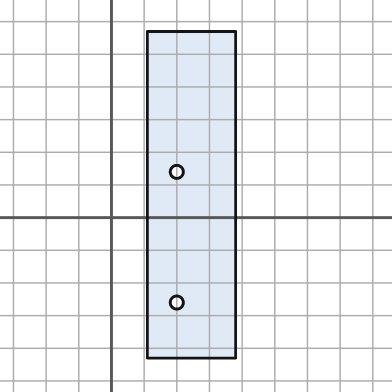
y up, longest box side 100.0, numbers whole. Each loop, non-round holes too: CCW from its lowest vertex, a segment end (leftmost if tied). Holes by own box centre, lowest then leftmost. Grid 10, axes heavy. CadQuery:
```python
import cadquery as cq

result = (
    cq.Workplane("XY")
    .moveTo(11.0, -43.0)
    .lineTo(38.0, -43.0)
    .lineTo(38.0, 57.0)
    .lineTo(11.0, 57.0)
    .close()
    .moveTo(20.0, -26.0)
    .circle(2.0)
    .moveTo(20.0, 14.0)
    .circle(2.0)
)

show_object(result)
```